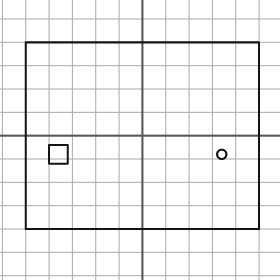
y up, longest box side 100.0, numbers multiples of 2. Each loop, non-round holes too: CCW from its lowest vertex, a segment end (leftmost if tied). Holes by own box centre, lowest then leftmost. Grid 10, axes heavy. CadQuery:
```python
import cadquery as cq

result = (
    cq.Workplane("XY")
    .moveTo(-50.0, -40.0)
    .lineTo(50.0, -40.0)
    .lineTo(50.0, 40.0)
    .lineTo(-50.0, 40.0)
    .close()
    .moveTo(-40.0, -12.0)
    .lineTo(-32.0, -12.0)
    .lineTo(-32.0, -4.0)
    .lineTo(-40.0, -4.0)
    .close()
    .moveTo(34.0, -8.0)
    .circle(2.0)
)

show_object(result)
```